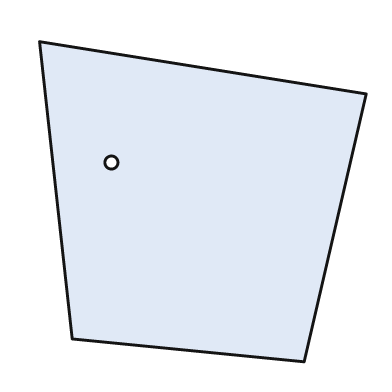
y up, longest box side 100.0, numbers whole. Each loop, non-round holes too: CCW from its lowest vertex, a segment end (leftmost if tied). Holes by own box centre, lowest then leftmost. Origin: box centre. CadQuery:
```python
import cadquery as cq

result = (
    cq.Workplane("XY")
    .moveTo(31.0, -49.0)
    .lineTo(50.0, 33.0)
    .lineTo(-50.0, 49.0)
    .lineTo(-40.0, -42.0)
    .close()
    .moveTo(-28.0, 12.0)
    .circle(2.0)
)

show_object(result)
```